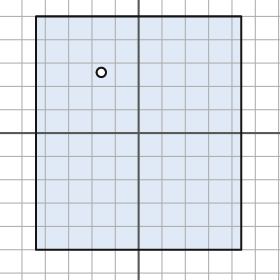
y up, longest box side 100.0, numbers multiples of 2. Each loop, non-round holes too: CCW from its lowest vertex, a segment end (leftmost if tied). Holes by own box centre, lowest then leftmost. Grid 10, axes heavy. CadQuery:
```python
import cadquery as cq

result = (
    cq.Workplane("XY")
    .moveTo(-44.0, -50.0)
    .lineTo(44.0, -50.0)
    .lineTo(44.0, 50.0)
    .lineTo(-44.0, 50.0)
    .close()
    .moveTo(-16.0, 26.0)
    .circle(2.0)
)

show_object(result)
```